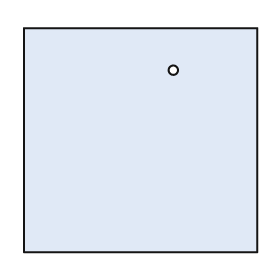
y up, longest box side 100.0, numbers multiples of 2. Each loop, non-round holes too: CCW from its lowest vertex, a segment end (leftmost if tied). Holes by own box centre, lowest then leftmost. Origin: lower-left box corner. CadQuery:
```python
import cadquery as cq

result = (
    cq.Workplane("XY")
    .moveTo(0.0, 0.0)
    .lineTo(100.0, 0.0)
    .lineTo(100.0, 96.0)
    .lineTo(0.0, 96.0)
    .close()
    .moveTo(64.0, 78.0)
    .circle(2.0)
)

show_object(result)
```